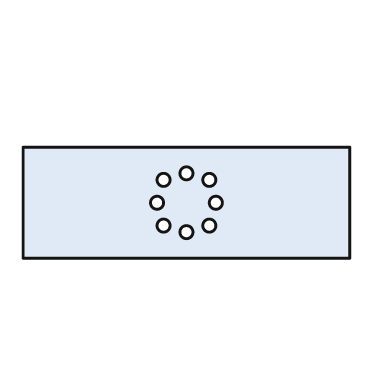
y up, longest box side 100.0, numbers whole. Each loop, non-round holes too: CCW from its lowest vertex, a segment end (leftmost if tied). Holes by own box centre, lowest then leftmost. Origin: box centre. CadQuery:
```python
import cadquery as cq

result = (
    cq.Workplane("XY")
    .moveTo(-50.0, -17.0)
    .lineTo(50.0, -17.0)
    .lineTo(50.0, 17.0)
    .lineTo(-50.0, 17.0)
    .close()
    .moveTo(0.0, -9.0)
    .circle(2.0)
    .moveTo(-7.0, -7.0)
    .circle(2.0)
    .moveTo(7.0, -7.0)
    .circle(2.0)
    .moveTo(-9.0, 0.0)
    .circle(2.0)
    .moveTo(9.0, 0.0)
    .circle(2.0)
    .moveTo(-7.0, 7.0)
    .circle(2.0)
    .moveTo(7.0, 7.0)
    .circle(2.0)
    .moveTo(0.0, 9.0)
    .circle(2.0)
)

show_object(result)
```